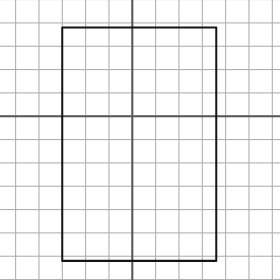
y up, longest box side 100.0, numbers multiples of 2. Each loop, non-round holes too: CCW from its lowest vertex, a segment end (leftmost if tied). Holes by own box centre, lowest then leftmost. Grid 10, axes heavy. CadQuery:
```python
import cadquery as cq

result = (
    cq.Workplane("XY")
    .moveTo(-30.0, -62.0)
    .lineTo(36.0, -62.0)
    .lineTo(36.0, 38.0)
    .lineTo(-30.0, 38.0)
    .close()
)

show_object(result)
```